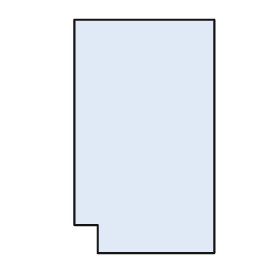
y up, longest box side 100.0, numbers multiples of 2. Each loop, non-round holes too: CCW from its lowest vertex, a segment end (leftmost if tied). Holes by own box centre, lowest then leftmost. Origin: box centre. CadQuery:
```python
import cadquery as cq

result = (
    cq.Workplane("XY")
    .moveTo(-20.0, -50.0)
    .lineTo(30.0, -50.0)
    .lineTo(30.0, 50.0)
    .lineTo(-30.0, 50.0)
    .lineTo(-30.0, -38.0)
    .lineTo(-20.0, -38.0)
    .close()
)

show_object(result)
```